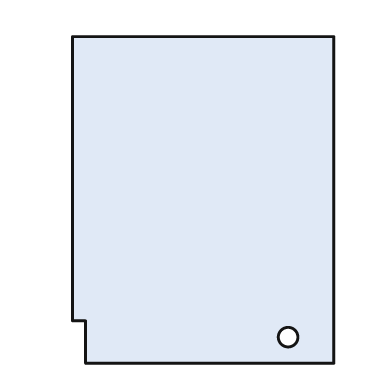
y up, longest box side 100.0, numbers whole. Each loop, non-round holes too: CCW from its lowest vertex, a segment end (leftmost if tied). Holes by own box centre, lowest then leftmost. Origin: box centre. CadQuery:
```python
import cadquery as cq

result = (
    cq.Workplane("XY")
    .moveTo(-36.0, -50.0)
    .lineTo(40.0, -50.0)
    .lineTo(40.0, 50.0)
    .lineTo(-40.0, 50.0)
    .lineTo(-40.0, -37.0)
    .lineTo(-36.0, -37.0)
    .close()
    .moveTo(26.0, -42.0)
    .circle(3.0)
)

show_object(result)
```